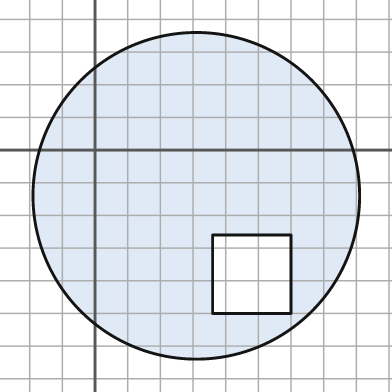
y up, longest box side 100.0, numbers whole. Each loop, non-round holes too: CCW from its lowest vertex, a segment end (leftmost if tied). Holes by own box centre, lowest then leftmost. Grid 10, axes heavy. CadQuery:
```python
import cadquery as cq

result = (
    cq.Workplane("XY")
    .moveTo(31.0, -14.0)
    .circle(50.0)
    .moveTo(36.0, -50.0)
    .lineTo(60.0, -50.0)
    .lineTo(60.0, -26.0)
    .lineTo(36.0, -26.0)
    .close()
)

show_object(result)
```